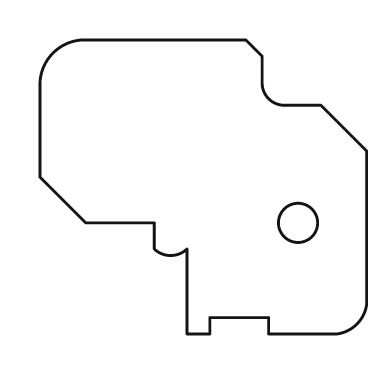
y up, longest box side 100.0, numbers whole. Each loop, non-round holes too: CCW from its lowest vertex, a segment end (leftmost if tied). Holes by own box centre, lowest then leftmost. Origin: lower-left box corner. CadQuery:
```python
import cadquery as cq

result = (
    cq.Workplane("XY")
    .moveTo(45.0, 0.0)
    .lineTo(52.0, 0.0)
    .lineTo(52.0, 5.0)
    .lineTo(70.0, 5.0)
    .lineTo(70.0, 0.0)
    .lineTo(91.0, 0.0)
    .threePointArc((97.0, 3.0), (100.0, 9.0))
    .lineTo(100.0, 56.0)
    .lineTo(86.0, 70.0)
    .lineTo(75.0, 70.0)
    .threePointArc((70.0, 72.0), (68.0, 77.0))
    .lineTo(68.0, 85.0)
    .lineTo(63.0, 90.0)
    .lineTo(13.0, 90.0)
    .threePointArc((4.0, 86.0), (0.0, 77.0))
    .lineTo(0.0, 48.0)
    .lineTo(14.0, 34.0)
    .lineTo(35.0, 34.0)
    .lineTo(35.0, 26.0)
    .threePointArc((40.0, 24.0), (45.0, 26.0))
    .close()
    .moveTo(79.0, 34.0)
    .circle(6.0)
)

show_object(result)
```